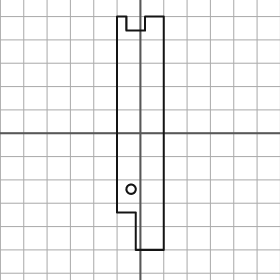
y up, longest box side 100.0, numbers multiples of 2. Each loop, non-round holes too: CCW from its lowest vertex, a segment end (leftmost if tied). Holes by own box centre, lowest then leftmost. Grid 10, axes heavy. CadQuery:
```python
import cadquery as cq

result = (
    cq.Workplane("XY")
    .moveTo(-2.0, -50.0)
    .lineTo(10.0, -50.0)
    .lineTo(10.0, 50.0)
    .lineTo(2.0, 50.0)
    .lineTo(2.0, 44.0)
    .lineTo(-6.0, 44.0)
    .lineTo(-6.0, 50.0)
    .lineTo(-10.0, 50.0)
    .lineTo(-10.0, -34.0)
    .lineTo(-2.0, -34.0)
    .close()
    .moveTo(-4.0, -24.0)
    .circle(2.0)
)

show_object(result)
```